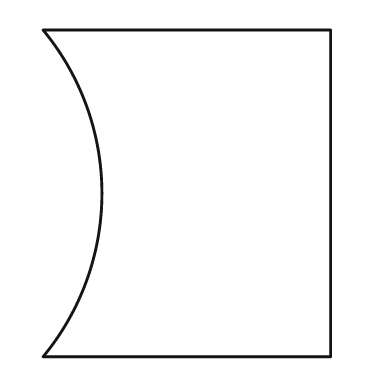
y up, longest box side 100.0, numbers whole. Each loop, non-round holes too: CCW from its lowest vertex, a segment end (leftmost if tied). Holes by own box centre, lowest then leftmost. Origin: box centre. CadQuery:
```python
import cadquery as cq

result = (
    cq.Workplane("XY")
    .moveTo(-44.0, -50.0)
    .lineTo(44.0, -50.0)
    .lineTo(44.0, 50.0)
    .lineTo(-44.0, 50.0)
    .threePointArc((-26.0, 0.0), (-44.0, -50.0))
    .close()
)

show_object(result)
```